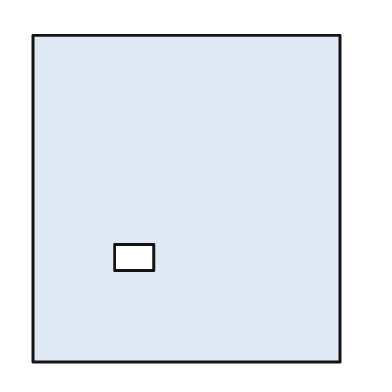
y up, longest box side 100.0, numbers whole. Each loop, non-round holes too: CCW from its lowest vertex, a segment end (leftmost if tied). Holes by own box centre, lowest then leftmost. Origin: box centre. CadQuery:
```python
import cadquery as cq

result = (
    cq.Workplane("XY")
    .moveTo(-47.0, -50.0)
    .lineTo(47.0, -50.0)
    .lineTo(47.0, 50.0)
    .lineTo(-47.0, 50.0)
    .close()
    .moveTo(-22.0, -22.0)
    .lineTo(-10.0, -22.0)
    .lineTo(-10.0, -14.0)
    .lineTo(-22.0, -14.0)
    .close()
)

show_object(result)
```